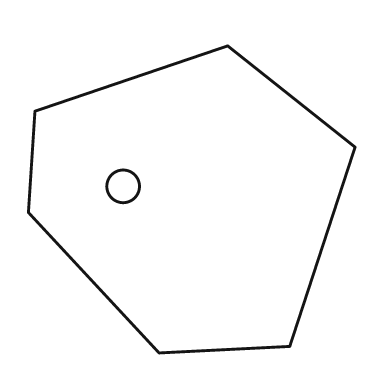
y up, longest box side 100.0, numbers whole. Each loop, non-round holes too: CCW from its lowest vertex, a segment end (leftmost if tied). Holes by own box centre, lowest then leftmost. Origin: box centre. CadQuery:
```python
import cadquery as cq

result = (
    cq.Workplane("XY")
    .moveTo(-10.0, -47.0)
    .lineTo(30.0, -45.0)
    .lineTo(50.0, 16.0)
    .lineTo(11.0, 47.0)
    .lineTo(-48.0, 27.0)
    .lineTo(-50.0, -4.0)
    .close()
    .moveTo(-21.0, 4.0)
    .circle(5.0)
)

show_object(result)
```